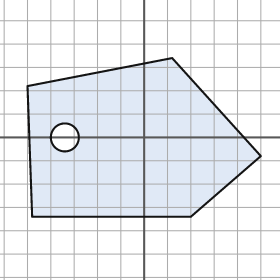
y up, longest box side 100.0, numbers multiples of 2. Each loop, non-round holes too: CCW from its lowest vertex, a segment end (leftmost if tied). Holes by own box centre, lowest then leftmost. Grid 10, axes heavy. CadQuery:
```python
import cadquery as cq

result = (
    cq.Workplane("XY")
    .moveTo(-48.0, -34.0)
    .lineTo(20.0, -34.0)
    .lineTo(50.0, -8.0)
    .lineTo(12.0, 34.0)
    .lineTo(-50.0, 22.0)
    .close()
    .moveTo(-34.0, 0.0)
    .circle(6.0)
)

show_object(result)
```